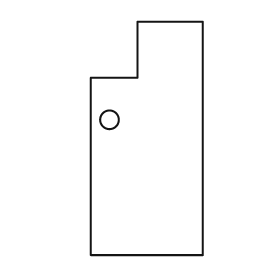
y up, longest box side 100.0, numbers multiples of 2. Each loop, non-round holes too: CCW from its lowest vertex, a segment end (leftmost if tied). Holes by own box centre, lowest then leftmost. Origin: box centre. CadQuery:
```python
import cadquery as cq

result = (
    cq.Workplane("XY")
    .moveTo(-24.0, -50.0)
    .lineTo(24.0, -50.0)
    .lineTo(24.0, 50.0)
    .lineTo(-4.0, 50.0)
    .lineTo(-4.0, 26.0)
    .lineTo(-24.0, 26.0)
    .close()
    .moveTo(-16.0, 8.0)
    .circle(4.0)
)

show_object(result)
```